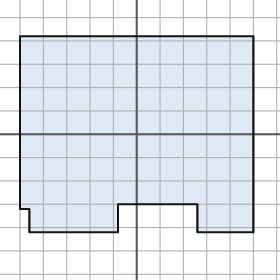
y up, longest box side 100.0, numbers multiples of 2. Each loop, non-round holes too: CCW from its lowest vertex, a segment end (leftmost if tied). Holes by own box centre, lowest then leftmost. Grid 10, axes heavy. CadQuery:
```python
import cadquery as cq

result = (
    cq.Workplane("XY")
    .moveTo(-46.0, -42.0)
    .lineTo(-8.0, -42.0)
    .lineTo(-8.0, -30.0)
    .lineTo(26.0, -30.0)
    .lineTo(26.0, -42.0)
    .lineTo(50.0, -42.0)
    .lineTo(50.0, 42.0)
    .lineTo(-50.0, 42.0)
    .lineTo(-50.0, -32.0)
    .lineTo(-46.0, -32.0)
    .close()
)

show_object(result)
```